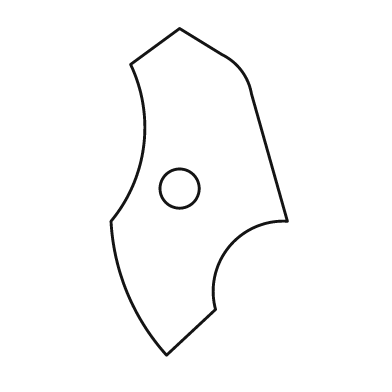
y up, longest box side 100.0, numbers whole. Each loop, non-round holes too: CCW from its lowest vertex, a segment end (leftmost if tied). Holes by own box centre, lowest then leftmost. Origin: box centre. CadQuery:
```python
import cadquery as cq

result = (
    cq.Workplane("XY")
    .moveTo(-10.0, -50.0)
    .lineTo(5.0, -36.0)
    .threePointArc((9.0, -17.0), (27.0, -9.0))
    .lineTo(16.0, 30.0)
    .threePointArc((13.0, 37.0), (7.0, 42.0))
    .lineTo(-6.0, 50.0)
    .lineTo(-21.0, 39.0)
    .threePointArc((-17.0, 14.0), (-27.0, -9.0))
    .threePointArc((-22.0, -31.0), (-10.0, -50.0))
    .close()
    .moveTo(-6.0, 1.0)
    .circle(6.0)
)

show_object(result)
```